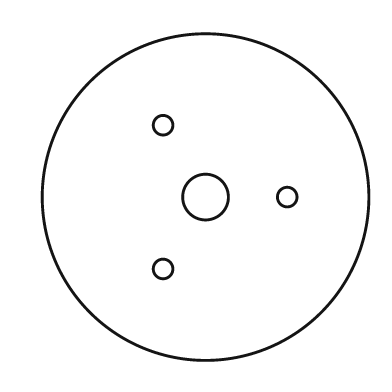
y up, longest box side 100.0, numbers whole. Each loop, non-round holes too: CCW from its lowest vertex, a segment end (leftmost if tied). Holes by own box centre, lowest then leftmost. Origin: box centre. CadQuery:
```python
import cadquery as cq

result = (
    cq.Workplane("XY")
    .moveTo(0.0, 0.0)
    .circle(50.0)
    .moveTo(-13.0, -22.0)
    .circle(3.0)
    .moveTo(0.0, 0.0)
    .circle(7.0)
    .moveTo(25.0, 0.0)
    .circle(3.0)
    .moveTo(-13.0, 22.0)
    .circle(3.0)
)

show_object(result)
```